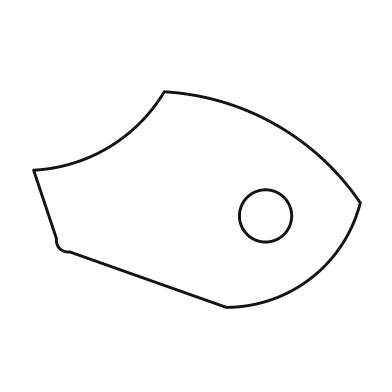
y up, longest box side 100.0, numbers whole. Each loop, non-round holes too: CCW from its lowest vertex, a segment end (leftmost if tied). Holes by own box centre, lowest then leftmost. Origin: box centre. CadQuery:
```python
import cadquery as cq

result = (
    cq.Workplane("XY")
    .moveTo(9.0, -33.0)
    .threePointArc((35.0, -24.0), (50.0, -1.0))
    .threePointArc((24.0, 23.0), (-10.0, 33.0))
    .threePointArc((-27.0, 16.0), (-50.0, 9.0))
    .lineTo(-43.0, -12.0)
    .threePointArc((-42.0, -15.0), (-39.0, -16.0))
    .close()
    .moveTo(21.0, -5.0)
    .circle(8.0)
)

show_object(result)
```